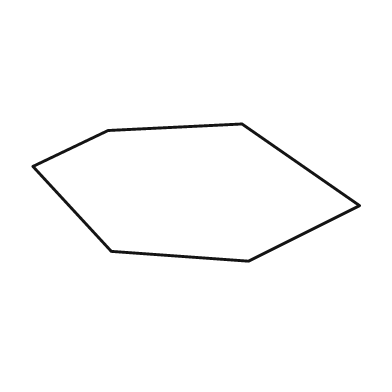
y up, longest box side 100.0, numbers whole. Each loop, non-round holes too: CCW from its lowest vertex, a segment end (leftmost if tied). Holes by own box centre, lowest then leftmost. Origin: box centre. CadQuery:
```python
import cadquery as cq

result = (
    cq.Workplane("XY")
    .moveTo(16.0, -21.0)
    .lineTo(50.0, -4.0)
    .lineTo(14.0, 21.0)
    .lineTo(-27.0, 19.0)
    .lineTo(-50.0, 8.0)
    .lineTo(-26.0, -18.0)
    .close()
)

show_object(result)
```